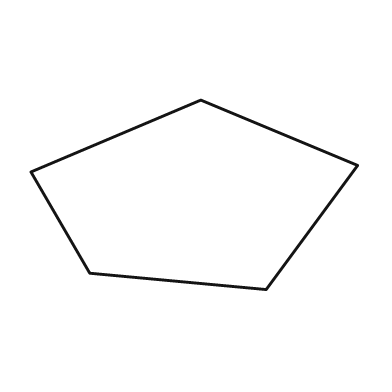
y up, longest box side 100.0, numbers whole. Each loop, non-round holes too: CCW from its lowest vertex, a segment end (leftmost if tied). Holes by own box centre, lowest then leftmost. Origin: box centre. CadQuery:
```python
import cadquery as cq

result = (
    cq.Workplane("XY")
    .moveTo(22.0, -29.0)
    .lineTo(50.0, 9.0)
    .lineTo(2.0, 29.0)
    .lineTo(-50.0, 7.0)
    .lineTo(-32.0, -24.0)
    .close()
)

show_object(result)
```